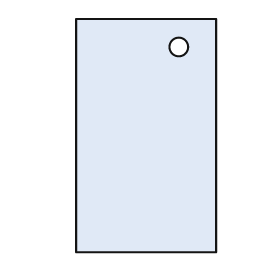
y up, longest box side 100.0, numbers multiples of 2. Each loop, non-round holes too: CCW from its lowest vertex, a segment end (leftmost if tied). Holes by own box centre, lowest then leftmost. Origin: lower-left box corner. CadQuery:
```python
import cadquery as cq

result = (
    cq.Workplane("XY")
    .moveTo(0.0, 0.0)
    .lineTo(60.0, 0.0)
    .lineTo(60.0, 100.0)
    .lineTo(0.0, 100.0)
    .close()
    .moveTo(44.0, 88.0)
    .circle(4.0)
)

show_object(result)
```